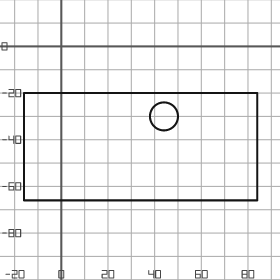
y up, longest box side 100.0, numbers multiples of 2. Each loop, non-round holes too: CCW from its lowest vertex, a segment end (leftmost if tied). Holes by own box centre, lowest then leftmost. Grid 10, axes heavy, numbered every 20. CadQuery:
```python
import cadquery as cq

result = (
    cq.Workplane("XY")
    .moveTo(-16.0, -66.0)
    .lineTo(84.0, -66.0)
    .lineTo(84.0, -20.0)
    .lineTo(-16.0, -20.0)
    .close()
    .moveTo(44.0, -30.0)
    .circle(6.0)
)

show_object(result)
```